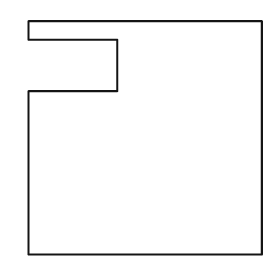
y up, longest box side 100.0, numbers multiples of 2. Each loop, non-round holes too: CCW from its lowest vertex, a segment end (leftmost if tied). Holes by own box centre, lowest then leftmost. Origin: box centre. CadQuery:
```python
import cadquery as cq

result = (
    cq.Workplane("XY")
    .moveTo(-50.0, -50.0)
    .lineTo(50.0, -50.0)
    .lineTo(50.0, 50.0)
    .lineTo(-50.0, 50.0)
    .lineTo(-50.0, 42.0)
    .lineTo(-12.0, 42.0)
    .lineTo(-12.0, 20.0)
    .lineTo(-50.0, 20.0)
    .close()
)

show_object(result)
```